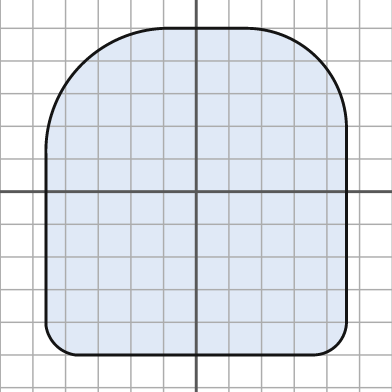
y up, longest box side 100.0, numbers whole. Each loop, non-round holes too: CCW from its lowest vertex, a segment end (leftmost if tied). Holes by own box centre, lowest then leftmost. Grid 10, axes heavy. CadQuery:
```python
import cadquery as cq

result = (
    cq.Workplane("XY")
    .moveTo(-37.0, -50.0)
    .lineTo(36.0, -50.0)
    .threePointArc((43.0, -47.0), (46.0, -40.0))
    .lineTo(46.0, 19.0)
    .threePointArc((37.0, 41.0), (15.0, 50.0))
    .lineTo(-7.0, 50.0)
    .threePointArc((-35.0, 39.0), (-46.0, 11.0))
    .lineTo(-46.0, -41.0)
    .threePointArc((-43.0, -47.0), (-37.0, -50.0))
    .close()
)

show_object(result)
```